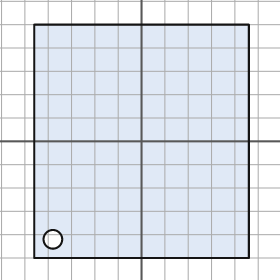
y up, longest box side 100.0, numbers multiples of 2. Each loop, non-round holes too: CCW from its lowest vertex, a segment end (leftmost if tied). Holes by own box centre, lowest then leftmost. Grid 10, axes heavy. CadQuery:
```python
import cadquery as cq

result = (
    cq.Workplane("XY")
    .moveTo(-46.0, -50.0)
    .lineTo(46.0, -50.0)
    .lineTo(46.0, 50.0)
    .lineTo(-46.0, 50.0)
    .close()
    .moveTo(-38.0, -42.0)
    .circle(4.0)
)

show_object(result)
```